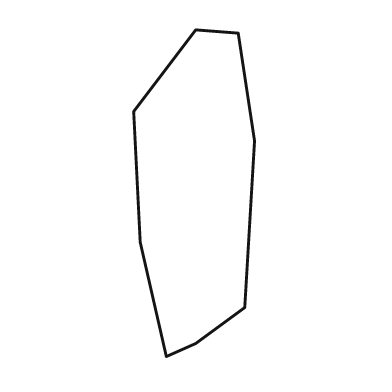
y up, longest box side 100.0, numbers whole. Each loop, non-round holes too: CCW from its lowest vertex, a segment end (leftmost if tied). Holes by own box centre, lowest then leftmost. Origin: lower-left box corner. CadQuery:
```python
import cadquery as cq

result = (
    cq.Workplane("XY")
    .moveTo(10.0, 0.0)
    .lineTo(19.0, 4.0)
    .lineTo(34.0, 15.0)
    .lineTo(37.0, 66.0)
    .lineTo(32.0, 99.0)
    .lineTo(19.0, 100.0)
    .lineTo(0.0, 75.0)
    .lineTo(2.0, 35.0)
    .close()
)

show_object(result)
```